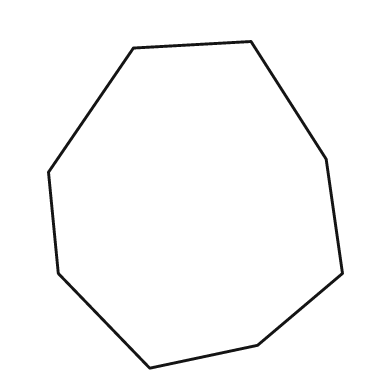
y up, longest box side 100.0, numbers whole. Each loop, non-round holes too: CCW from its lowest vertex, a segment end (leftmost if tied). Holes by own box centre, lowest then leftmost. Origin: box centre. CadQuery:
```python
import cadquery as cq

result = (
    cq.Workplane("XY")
    .moveTo(-14.0, -50.0)
    .lineTo(19.0, -43.0)
    .lineTo(45.0, -21.0)
    .lineTo(40.0, 14.0)
    .lineTo(17.0, 50.0)
    .lineTo(-19.0, 48.0)
    .lineTo(-45.0, 10.0)
    .lineTo(-42.0, -21.0)
    .close()
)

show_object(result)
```